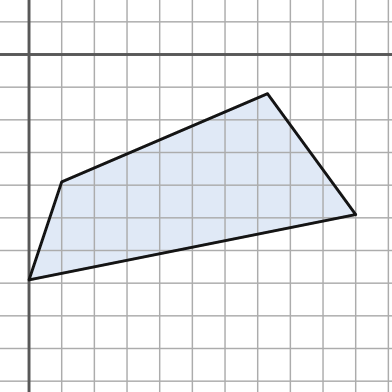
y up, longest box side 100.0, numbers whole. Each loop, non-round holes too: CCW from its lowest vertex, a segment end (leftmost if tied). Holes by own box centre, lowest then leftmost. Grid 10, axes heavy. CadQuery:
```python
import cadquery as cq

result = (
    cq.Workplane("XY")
    .moveTo(0.0, -69.0)
    .lineTo(100.0, -49.0)
    .lineTo(73.0, -12.0)
    .lineTo(10.0, -39.0)
    .close()
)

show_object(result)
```